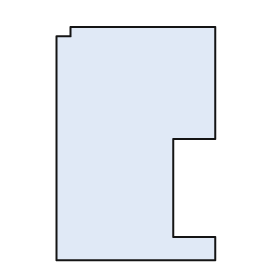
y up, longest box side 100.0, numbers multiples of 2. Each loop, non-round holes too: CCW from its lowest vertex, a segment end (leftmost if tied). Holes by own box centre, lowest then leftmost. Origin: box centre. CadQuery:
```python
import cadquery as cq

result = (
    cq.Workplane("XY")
    .moveTo(-34.0, -50.0)
    .lineTo(34.0, -50.0)
    .lineTo(34.0, -40.0)
    .lineTo(16.0, -40.0)
    .lineTo(16.0, 2.0)
    .lineTo(34.0, 2.0)
    .lineTo(34.0, 50.0)
    .lineTo(-28.0, 50.0)
    .lineTo(-28.0, 46.0)
    .lineTo(-34.0, 46.0)
    .close()
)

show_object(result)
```